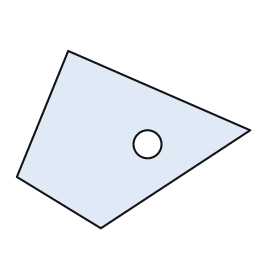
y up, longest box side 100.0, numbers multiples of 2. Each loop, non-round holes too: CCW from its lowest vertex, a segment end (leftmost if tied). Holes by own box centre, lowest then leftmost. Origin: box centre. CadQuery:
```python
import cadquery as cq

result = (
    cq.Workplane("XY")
    .moveTo(-14.0, -38.0)
    .lineTo(50.0, 4.0)
    .lineTo(-28.0, 38.0)
    .lineTo(-50.0, -16.0)
    .close()
    .moveTo(6.0, -2.0)
    .circle(6.0)
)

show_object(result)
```